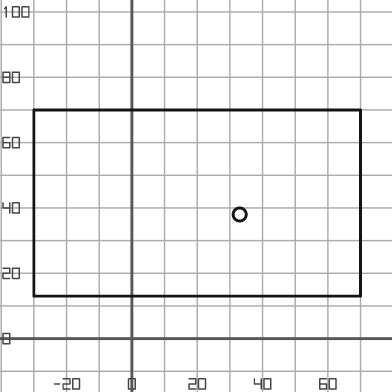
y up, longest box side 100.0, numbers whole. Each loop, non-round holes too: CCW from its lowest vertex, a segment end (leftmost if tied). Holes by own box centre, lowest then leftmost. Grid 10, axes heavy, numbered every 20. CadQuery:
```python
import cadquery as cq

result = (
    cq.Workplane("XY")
    .moveTo(-30.0, 13.0)
    .lineTo(70.0, 13.0)
    .lineTo(70.0, 70.0)
    .lineTo(-30.0, 70.0)
    .close()
    .moveTo(33.0, 38.0)
    .circle(2.0)
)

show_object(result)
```